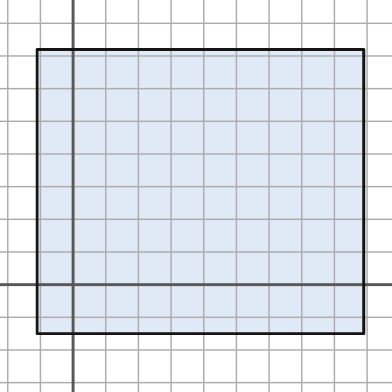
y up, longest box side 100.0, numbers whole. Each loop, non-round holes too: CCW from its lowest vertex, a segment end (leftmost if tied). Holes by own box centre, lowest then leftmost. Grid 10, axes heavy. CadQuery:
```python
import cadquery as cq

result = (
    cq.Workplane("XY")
    .moveTo(-11.0, -15.0)
    .lineTo(89.0, -15.0)
    .lineTo(89.0, 72.0)
    .lineTo(-11.0, 72.0)
    .close()
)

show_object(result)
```